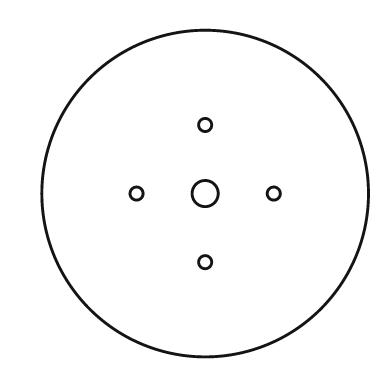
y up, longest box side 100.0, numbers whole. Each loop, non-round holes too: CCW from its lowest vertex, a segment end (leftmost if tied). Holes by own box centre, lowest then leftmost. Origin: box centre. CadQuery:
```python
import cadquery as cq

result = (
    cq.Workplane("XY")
    .moveTo(0.0, 0.0)
    .circle(50.0)
    .moveTo(0.0, -21.0)
    .circle(2.0)
    .moveTo(-21.0, 0.0)
    .circle(2.0)
    .moveTo(0.0, 0.0)
    .circle(4.0)
    .moveTo(21.0, 0.0)
    .circle(2.0)
    .moveTo(0.0, 21.0)
    .circle(2.0)
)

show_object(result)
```